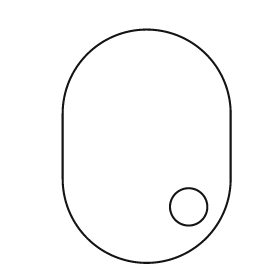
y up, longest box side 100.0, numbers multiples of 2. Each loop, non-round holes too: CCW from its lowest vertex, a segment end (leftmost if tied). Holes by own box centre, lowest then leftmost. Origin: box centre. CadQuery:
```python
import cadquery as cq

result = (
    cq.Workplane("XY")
    .moveTo(-36.0, -14.0)
    .threePointArc((0.0, -50.0), (36.0, -14.0))
    .lineTo(36.0, 14.0)
    .threePointArc((0.0, 50.0), (-36.0, 14.0))
    .close()
    .moveTo(18.0, -26.0)
    .circle(8.0)
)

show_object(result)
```